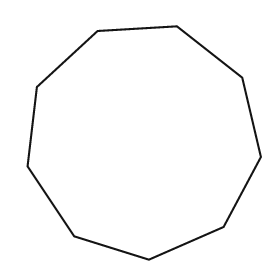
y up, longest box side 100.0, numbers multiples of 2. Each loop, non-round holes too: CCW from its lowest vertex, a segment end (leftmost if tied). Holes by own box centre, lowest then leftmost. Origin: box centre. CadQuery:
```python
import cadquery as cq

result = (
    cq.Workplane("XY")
    .moveTo(2.0, -50.0)
    .lineTo(34.0, -36.0)
    .lineTo(50.0, -6.0)
    .lineTo(42.0, 28.0)
    .lineTo(14.0, 50.0)
    .lineTo(-20.0, 48.0)
    .lineTo(-46.0, 24.0)
    .lineTo(-50.0, -10.0)
    .lineTo(-30.0, -40.0)
    .close()
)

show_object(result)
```